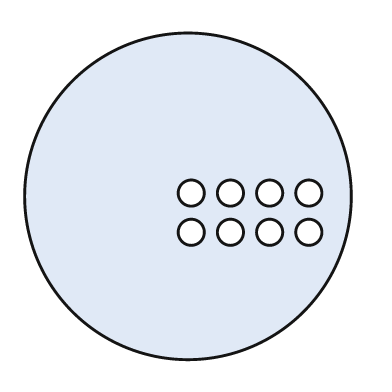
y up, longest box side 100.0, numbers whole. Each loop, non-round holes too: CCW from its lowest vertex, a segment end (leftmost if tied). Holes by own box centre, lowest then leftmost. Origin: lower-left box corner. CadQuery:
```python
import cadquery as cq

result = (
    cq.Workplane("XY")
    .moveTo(50.0, 50.0)
    .circle(50.0)
    .moveTo(51.0, 39.0)
    .circle(4.0)
    .moveTo(63.0, 39.0)
    .circle(4.0)
    .moveTo(75.0, 39.0)
    .circle(4.0)
    .moveTo(87.0, 39.0)
    .circle(4.0)
    .moveTo(51.0, 51.0)
    .circle(4.0)
    .moveTo(63.0, 51.0)
    .circle(4.0)
    .moveTo(75.0, 51.0)
    .circle(4.0)
    .moveTo(87.0, 51.0)
    .circle(4.0)
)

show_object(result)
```